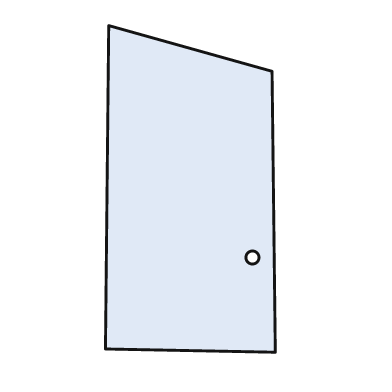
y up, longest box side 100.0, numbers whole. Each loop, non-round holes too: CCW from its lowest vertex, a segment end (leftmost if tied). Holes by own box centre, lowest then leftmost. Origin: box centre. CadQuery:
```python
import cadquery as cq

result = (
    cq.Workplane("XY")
    .moveTo(26.0, -50.0)
    .lineTo(25.0, 36.0)
    .lineTo(-25.0, 50.0)
    .lineTo(-26.0, -49.0)
    .close()
    .moveTo(19.0, -21.0)
    .circle(2.0)
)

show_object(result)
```